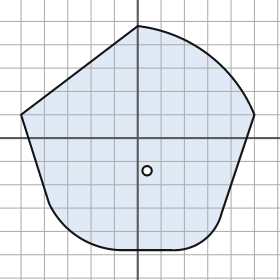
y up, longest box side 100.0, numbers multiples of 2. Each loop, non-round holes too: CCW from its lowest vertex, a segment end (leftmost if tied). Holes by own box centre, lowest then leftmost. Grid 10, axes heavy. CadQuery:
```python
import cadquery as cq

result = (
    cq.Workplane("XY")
    .moveTo(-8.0, -48.0)
    .lineTo(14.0, -48.0)
    .threePointArc((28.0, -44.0), (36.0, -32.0))
    .lineTo(50.0, 10.0)
    .threePointArc((30.0, 36.0), (0.0, 48.0))
    .lineTo(-50.0, 10.0)
    .lineTo(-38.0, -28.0)
    .threePointArc((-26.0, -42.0), (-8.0, -48.0))
    .close()
    .moveTo(4.0, -14.0)
    .circle(2.0)
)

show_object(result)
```